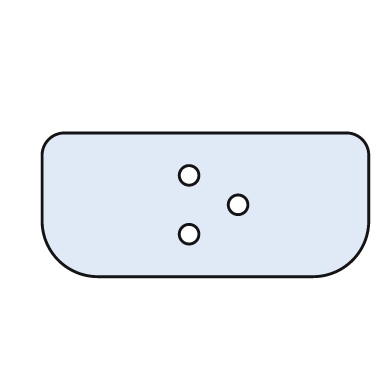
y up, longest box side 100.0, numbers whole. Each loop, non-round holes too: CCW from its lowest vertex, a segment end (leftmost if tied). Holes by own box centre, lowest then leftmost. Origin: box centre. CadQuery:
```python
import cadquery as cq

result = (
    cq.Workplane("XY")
    .moveTo(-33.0, -22.0)
    .lineTo(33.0, -22.0)
    .threePointArc((45.0, -17.0), (50.0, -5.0))
    .lineTo(50.0, 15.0)
    .threePointArc((48.0, 20.0), (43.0, 22.0))
    .lineTo(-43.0, 22.0)
    .threePointArc((-48.0, 20.0), (-50.0, 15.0))
    .lineTo(-50.0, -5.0)
    .threePointArc((-45.0, -17.0), (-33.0, -22.0))
    .close()
    .moveTo(-5.0, -9.0)
    .circle(3.0)
    .moveTo(10.0, 0.0)
    .circle(3.0)
    .moveTo(-5.0, 9.0)
    .circle(3.0)
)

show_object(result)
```